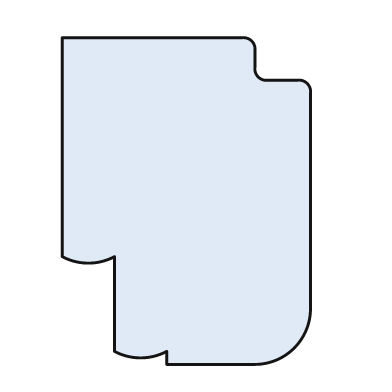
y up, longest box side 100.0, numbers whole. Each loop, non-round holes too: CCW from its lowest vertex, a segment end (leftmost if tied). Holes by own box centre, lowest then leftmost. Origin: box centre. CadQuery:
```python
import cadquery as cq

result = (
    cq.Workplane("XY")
    .moveTo(-6.0, -50.0)
    .lineTo(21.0, -50.0)
    .threePointArc((33.0, -45.0), (38.0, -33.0))
    .lineTo(38.0, 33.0)
    .threePointArc((37.0, 36.0), (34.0, 37.0))
    .lineTo(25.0, 37.0)
    .threePointArc((22.0, 38.0), (21.0, 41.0))
    .lineTo(21.0, 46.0)
    .threePointArc((20.0, 49.0), (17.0, 50.0))
    .lineTo(-38.0, 50.0)
    .lineTo(-38.0, -17.0)
    .threePointArc((-30.0, -19.0), (-22.0, -17.0))
    .lineTo(-22.0, -46.0)
    .threePointArc((-14.0, -48.0), (-6.0, -46.0))
    .close()
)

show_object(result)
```